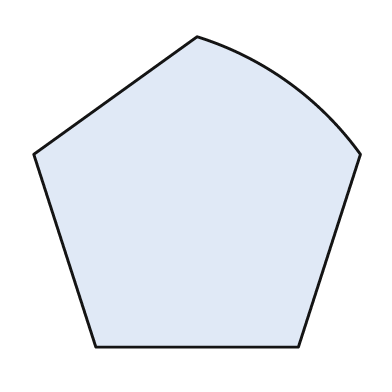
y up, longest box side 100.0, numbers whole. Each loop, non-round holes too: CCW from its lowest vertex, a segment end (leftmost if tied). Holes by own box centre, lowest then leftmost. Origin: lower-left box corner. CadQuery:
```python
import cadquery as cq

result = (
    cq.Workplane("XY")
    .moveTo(19.0, 0.0)
    .lineTo(81.0, 0.0)
    .lineTo(100.0, 59.0)
    .threePointArc((78.0, 81.0), (50.0, 95.0))
    .lineTo(0.0, 59.0)
    .close()
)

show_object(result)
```